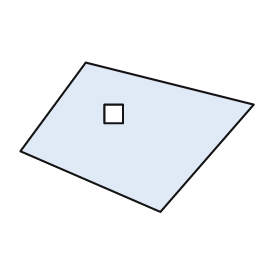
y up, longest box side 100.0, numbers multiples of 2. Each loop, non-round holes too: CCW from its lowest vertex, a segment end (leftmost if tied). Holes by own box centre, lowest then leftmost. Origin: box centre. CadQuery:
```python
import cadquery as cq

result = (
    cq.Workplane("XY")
    .moveTo(10.0, -32.0)
    .lineTo(50.0, 14.0)
    .lineTo(-22.0, 32.0)
    .lineTo(-50.0, -6.0)
    .close()
    .moveTo(-14.0, 6.0)
    .lineTo(-6.0, 6.0)
    .lineTo(-6.0, 14.0)
    .lineTo(-14.0, 14.0)
    .close()
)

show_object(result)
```